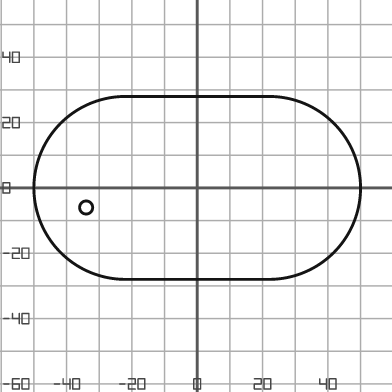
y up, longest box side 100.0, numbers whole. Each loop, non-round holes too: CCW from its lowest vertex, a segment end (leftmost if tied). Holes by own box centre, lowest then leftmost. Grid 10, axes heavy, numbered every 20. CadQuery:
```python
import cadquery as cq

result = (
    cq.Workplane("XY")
    .moveTo(-22.0, -28.0)
    .lineTo(22.0, -28.0)
    .threePointArc((50.0, 0.0), (22.0, 28.0))
    .lineTo(-22.0, 28.0)
    .threePointArc((-50.0, 0.0), (-22.0, -28.0))
    .close()
    .moveTo(-34.0, -6.0)
    .circle(2.0)
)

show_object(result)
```